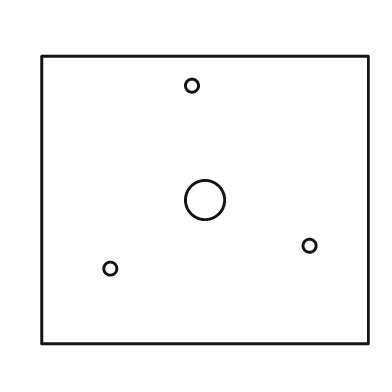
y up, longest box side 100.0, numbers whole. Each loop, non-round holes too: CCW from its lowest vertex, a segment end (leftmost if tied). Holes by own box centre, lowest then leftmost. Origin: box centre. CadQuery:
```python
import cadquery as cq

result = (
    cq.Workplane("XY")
    .moveTo(-50.0, -44.0)
    .lineTo(50.0, -44.0)
    .lineTo(50.0, 44.0)
    .lineTo(-50.0, 44.0)
    .close()
    .moveTo(-29.0, -21.0)
    .circle(2.0)
    .moveTo(32.0, -14.0)
    .circle(2.0)
    .moveTo(0.0, 0.0)
    .circle(6.0)
    .moveTo(-4.0, 35.0)
    .circle(2.0)
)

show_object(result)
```